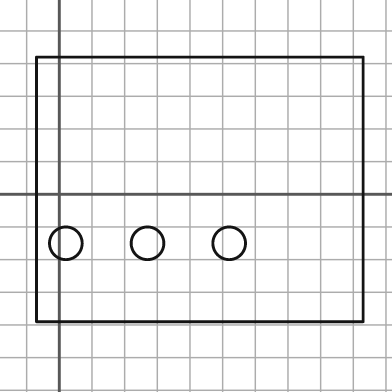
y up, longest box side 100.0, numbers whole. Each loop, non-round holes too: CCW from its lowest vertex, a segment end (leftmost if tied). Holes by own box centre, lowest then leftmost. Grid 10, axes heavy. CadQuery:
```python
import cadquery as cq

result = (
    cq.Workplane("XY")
    .moveTo(-7.0, -39.0)
    .lineTo(93.0, -39.0)
    .lineTo(93.0, 42.0)
    .lineTo(-7.0, 42.0)
    .close()
    .moveTo(2.0, -15.0)
    .circle(5.0)
    .moveTo(27.0, -15.0)
    .circle(5.0)
    .moveTo(52.0, -15.0)
    .circle(5.0)
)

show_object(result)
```